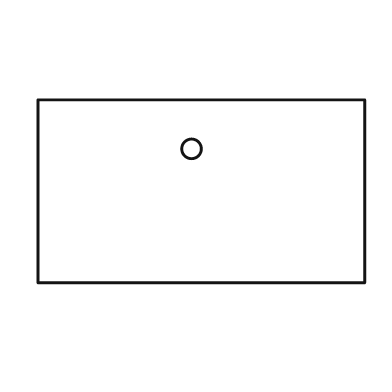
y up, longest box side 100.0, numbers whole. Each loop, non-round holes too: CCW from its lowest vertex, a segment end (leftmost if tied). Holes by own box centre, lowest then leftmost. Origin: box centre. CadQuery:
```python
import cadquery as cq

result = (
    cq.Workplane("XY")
    .moveTo(-50.0, -28.0)
    .lineTo(50.0, -28.0)
    .lineTo(50.0, 28.0)
    .lineTo(-50.0, 28.0)
    .close()
    .moveTo(-3.0, 13.0)
    .circle(3.0)
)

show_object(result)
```